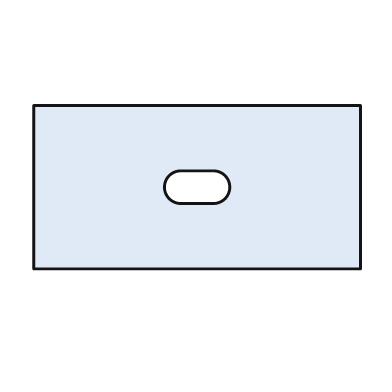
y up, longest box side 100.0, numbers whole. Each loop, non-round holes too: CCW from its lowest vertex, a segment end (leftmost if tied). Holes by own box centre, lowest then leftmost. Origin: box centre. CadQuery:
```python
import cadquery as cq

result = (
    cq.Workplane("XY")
    .moveTo(-50.0, -25.0)
    .lineTo(50.0, -25.0)
    .lineTo(50.0, 25.0)
    .lineTo(-50.0, 25.0)
    .close()
    .moveTo(-5.0, -5.0)
    .lineTo(5.0, -5.0)
    .threePointArc((10.0, 0.0), (5.0, 5.0))
    .lineTo(-5.0, 5.0)
    .threePointArc((-10.0, 0.0), (-5.0, -5.0))
    .close()
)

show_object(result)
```